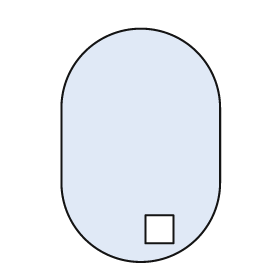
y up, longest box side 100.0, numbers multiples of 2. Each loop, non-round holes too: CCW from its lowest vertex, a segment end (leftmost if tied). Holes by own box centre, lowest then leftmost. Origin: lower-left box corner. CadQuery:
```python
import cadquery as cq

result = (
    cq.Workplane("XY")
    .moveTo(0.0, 34.0)
    .threePointArc((34.0, 0.0), (68.0, 34.0))
    .lineTo(68.0, 66.0)
    .threePointArc((34.0, 100.0), (0.0, 66.0))
    .close()
    .moveTo(36.0, 8.0)
    .lineTo(48.0, 8.0)
    .lineTo(48.0, 20.0)
    .lineTo(36.0, 20.0)
    .close()
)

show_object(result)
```